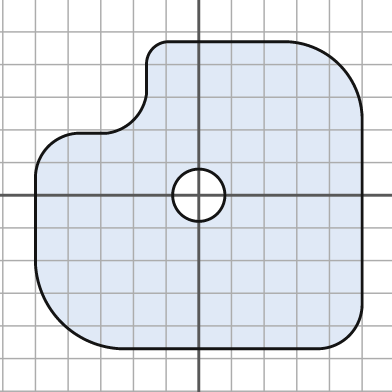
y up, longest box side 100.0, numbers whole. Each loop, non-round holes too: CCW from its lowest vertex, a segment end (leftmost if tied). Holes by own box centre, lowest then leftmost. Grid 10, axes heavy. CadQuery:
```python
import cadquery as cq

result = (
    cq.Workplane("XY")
    .moveTo(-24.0, -47.0)
    .lineTo(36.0, -47.0)
    .threePointArc((46.0, -43.0), (50.0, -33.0))
    .lineTo(50.0, 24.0)
    .threePointArc((43.0, 40.0), (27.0, 47.0))
    .lineTo(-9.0, 47.0)
    .threePointArc((-14.0, 45.0), (-16.0, 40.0))
    .lineTo(-16.0, 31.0)
    .threePointArc((-20.0, 23.0), (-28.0, 19.0))
    .lineTo(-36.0, 19.0)
    .threePointArc((-46.0, 15.0), (-50.0, 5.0))
    .lineTo(-50.0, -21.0)
    .threePointArc((-42.0, -39.0), (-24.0, -47.0))
    .close()
    .moveTo(0.0, 0.0)
    .circle(8.0)
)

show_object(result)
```